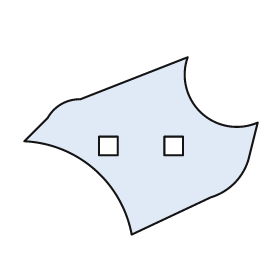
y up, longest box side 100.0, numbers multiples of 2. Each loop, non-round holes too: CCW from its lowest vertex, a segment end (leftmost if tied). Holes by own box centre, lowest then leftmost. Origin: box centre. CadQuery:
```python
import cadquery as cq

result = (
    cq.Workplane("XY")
    .moveTo(-4.0, -38.0)
    .lineTo(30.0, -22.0)
    .threePointArc((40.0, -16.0), (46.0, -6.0))
    .lineTo(50.0, 10.0)
    .threePointArc((26.0, 14.0), (20.0, 38.0))
    .lineTo(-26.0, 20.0)
    .threePointArc((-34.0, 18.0), (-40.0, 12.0))
    .lineTo(-50.0, 2.0)
    .threePointArc((-20.0, -10.0), (-4.0, -38.0))
    .close()
    .moveTo(-18.0, -4.0)
    .lineTo(-10.0, -4.0)
    .lineTo(-10.0, 4.0)
    .lineTo(-18.0, 4.0)
    .close()
    .moveTo(10.0, -4.0)
    .lineTo(18.0, -4.0)
    .lineTo(18.0, 4.0)
    .lineTo(10.0, 4.0)
    .close()
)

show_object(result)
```